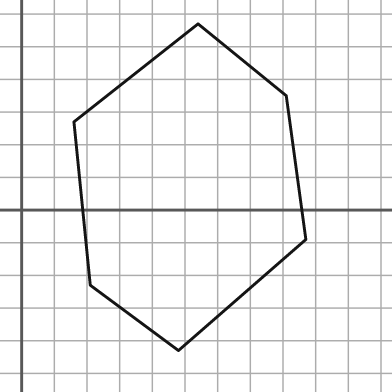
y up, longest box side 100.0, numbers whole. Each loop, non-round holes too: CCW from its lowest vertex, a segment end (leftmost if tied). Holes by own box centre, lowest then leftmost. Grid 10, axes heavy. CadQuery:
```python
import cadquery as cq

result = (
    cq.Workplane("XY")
    .moveTo(48.0, -43.0)
    .lineTo(87.0, -9.0)
    .lineTo(81.0, 35.0)
    .lineTo(54.0, 57.0)
    .lineTo(16.0, 27.0)
    .lineTo(21.0, -23.0)
    .close()
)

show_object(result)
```